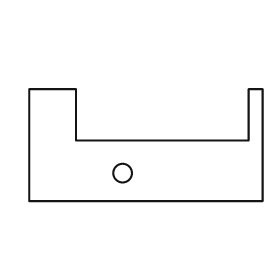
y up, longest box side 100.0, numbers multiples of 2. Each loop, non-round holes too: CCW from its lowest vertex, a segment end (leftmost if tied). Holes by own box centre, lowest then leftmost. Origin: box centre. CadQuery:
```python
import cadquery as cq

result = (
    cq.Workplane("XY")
    .moveTo(-50.0, -24.0)
    .lineTo(50.0, -24.0)
    .lineTo(50.0, 24.0)
    .lineTo(44.0, 24.0)
    .lineTo(44.0, 2.0)
    .lineTo(-30.0, 2.0)
    .lineTo(-30.0, 24.0)
    .lineTo(-50.0, 24.0)
    .close()
    .moveTo(-10.0, -12.0)
    .circle(4.0)
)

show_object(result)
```